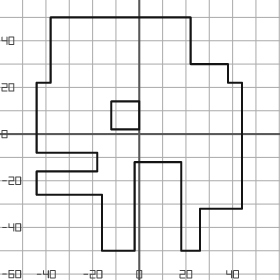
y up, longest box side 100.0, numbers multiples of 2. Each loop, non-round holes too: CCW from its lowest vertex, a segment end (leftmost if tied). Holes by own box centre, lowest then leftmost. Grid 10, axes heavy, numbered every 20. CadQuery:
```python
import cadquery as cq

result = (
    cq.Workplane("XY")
    .moveTo(-16.0, -50.0)
    .lineTo(-2.0, -50.0)
    .lineTo(-2.0, -12.0)
    .lineTo(18.0, -12.0)
    .lineTo(18.0, -50.0)
    .lineTo(26.0, -50.0)
    .lineTo(26.0, -32.0)
    .lineTo(44.0, -32.0)
    .lineTo(44.0, 22.0)
    .lineTo(38.0, 22.0)
    .lineTo(38.0, 30.0)
    .lineTo(22.0, 30.0)
    .lineTo(22.0, 50.0)
    .lineTo(-38.0, 50.0)
    .lineTo(-38.0, 22.0)
    .lineTo(-44.0, 22.0)
    .lineTo(-44.0, -8.0)
    .lineTo(-18.0, -8.0)
    .lineTo(-18.0, -16.0)
    .lineTo(-44.0, -16.0)
    .lineTo(-44.0, -26.0)
    .lineTo(-16.0, -26.0)
    .close()
    .moveTo(-12.0, 2.0)
    .lineTo(0.0, 2.0)
    .lineTo(0.0, 14.0)
    .lineTo(-12.0, 14.0)
    .close()
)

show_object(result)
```